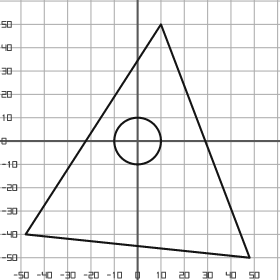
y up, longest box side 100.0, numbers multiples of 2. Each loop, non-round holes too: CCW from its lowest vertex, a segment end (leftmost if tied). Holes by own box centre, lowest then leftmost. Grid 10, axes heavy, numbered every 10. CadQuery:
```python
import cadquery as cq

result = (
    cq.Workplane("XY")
    .moveTo(48.0, -50.0)
    .lineTo(10.0, 50.0)
    .lineTo(-48.0, -40.0)
    .close()
    .moveTo(0.0, 0.0)
    .circle(10.0)
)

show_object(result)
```